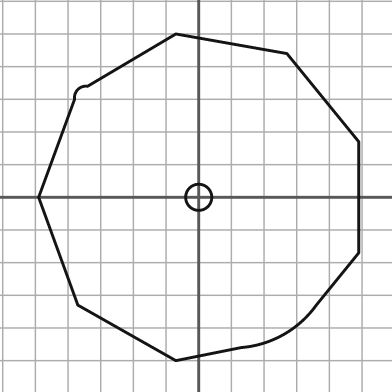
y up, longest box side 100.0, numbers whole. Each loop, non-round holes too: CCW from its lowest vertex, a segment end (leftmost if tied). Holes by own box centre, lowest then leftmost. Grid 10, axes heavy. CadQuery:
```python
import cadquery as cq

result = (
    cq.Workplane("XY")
    .moveTo(-7.0, -50.0)
    .lineTo(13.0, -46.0)
    .threePointArc((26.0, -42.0), (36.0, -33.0))
    .lineTo(49.0, -17.0)
    .lineTo(49.0, 17.0)
    .lineTo(27.0, 44.0)
    .lineTo(-7.0, 50.0)
    .lineTo(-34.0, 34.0)
    .threePointArc((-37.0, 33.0), (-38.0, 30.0))
    .lineTo(-49.0, 0.0)
    .lineTo(-37.0, -33.0)
    .close()
    .moveTo(0.0, 0.0)
    .circle(4.0)
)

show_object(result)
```